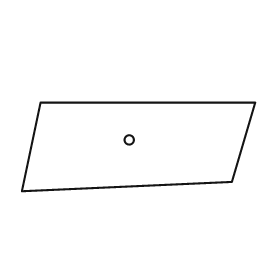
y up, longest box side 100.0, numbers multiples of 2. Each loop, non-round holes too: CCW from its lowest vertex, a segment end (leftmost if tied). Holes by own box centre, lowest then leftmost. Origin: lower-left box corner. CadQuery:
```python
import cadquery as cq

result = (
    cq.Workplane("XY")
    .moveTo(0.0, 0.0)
    .lineTo(90.0, 4.0)
    .lineTo(100.0, 38.0)
    .lineTo(8.0, 38.0)
    .close()
    .moveTo(46.0, 22.0)
    .circle(2.0)
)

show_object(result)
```